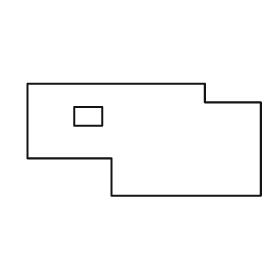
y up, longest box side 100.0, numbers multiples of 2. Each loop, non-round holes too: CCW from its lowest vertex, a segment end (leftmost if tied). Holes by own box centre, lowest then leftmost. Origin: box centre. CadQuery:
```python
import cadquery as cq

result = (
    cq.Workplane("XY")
    .moveTo(-14.0, -24.0)
    .lineTo(50.0, -24.0)
    .lineTo(50.0, 16.0)
    .lineTo(26.0, 16.0)
    .lineTo(26.0, 24.0)
    .lineTo(-50.0, 24.0)
    .lineTo(-50.0, -8.0)
    .lineTo(-14.0, -8.0)
    .close()
    .moveTo(-30.0, 6.0)
    .lineTo(-18.0, 6.0)
    .lineTo(-18.0, 14.0)
    .lineTo(-30.0, 14.0)
    .close()
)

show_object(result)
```